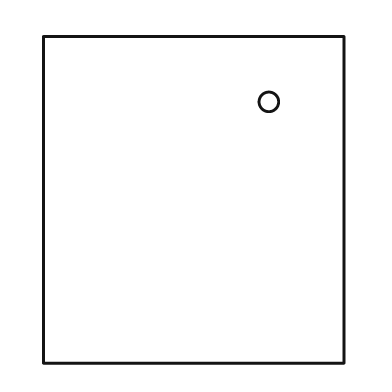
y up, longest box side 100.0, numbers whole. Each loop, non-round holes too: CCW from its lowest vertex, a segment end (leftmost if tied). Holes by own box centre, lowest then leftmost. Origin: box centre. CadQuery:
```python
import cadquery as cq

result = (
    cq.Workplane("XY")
    .moveTo(-46.0, -50.0)
    .lineTo(46.0, -50.0)
    .lineTo(46.0, 50.0)
    .lineTo(-46.0, 50.0)
    .close()
    .moveTo(23.0, 30.0)
    .circle(3.0)
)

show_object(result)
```